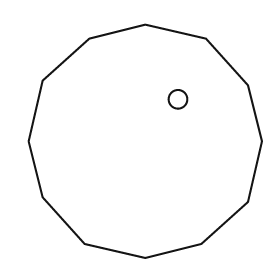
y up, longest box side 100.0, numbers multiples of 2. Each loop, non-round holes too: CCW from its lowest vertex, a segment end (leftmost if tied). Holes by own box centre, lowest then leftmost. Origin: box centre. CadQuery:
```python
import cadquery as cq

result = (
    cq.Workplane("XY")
    .moveTo(0.0, -50.0)
    .lineTo(24.0, -44.0)
    .lineTo(44.0, -26.0)
    .lineTo(50.0, 0.0)
    .lineTo(44.0, 24.0)
    .lineTo(26.0, 44.0)
    .lineTo(0.0, 50.0)
    .lineTo(-24.0, 44.0)
    .lineTo(-44.0, 26.0)
    .lineTo(-50.0, 0.0)
    .lineTo(-44.0, -24.0)
    .lineTo(-26.0, -44.0)
    .close()
    .moveTo(14.0, 18.0)
    .circle(4.0)
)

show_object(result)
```